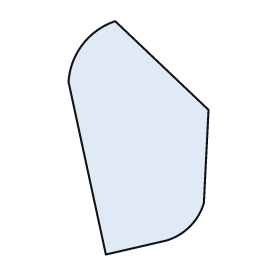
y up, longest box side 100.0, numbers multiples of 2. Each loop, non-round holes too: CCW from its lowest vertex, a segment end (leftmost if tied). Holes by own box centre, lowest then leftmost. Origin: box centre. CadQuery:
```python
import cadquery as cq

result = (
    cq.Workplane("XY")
    .moveTo(-14.0, -50.0)
    .lineTo(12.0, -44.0)
    .threePointArc((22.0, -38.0), (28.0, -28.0))
    .lineTo(30.0, 12.0)
    .lineTo(-10.0, 50.0)
    .threePointArc((-24.0, 40.0), (-30.0, 24.0))
    .close()
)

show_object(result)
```